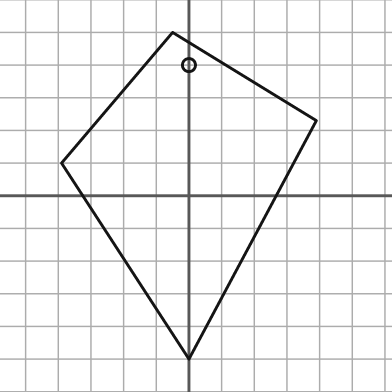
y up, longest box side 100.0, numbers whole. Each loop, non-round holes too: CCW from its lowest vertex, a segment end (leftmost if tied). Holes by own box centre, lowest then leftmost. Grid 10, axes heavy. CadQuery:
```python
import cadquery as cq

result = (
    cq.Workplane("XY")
    .moveTo(0.0, -50.0)
    .lineTo(39.0, 23.0)
    .lineTo(-5.0, 50.0)
    .lineTo(-39.0, 10.0)
    .close()
    .moveTo(0.0, 40.0)
    .circle(2.0)
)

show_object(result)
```